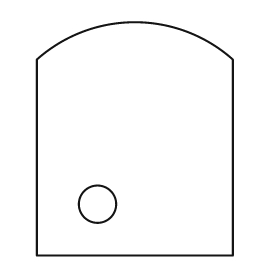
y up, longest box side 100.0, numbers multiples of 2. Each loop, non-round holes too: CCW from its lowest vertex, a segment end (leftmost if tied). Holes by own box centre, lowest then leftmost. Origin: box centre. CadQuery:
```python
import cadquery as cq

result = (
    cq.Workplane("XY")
    .moveTo(-42.0, -50.0)
    .lineTo(42.0, -50.0)
    .lineTo(42.0, 34.0)
    .threePointArc((0.0, 50.0), (-42.0, 34.0))
    .close()
    .moveTo(-16.0, -28.0)
    .circle(8.0)
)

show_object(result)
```